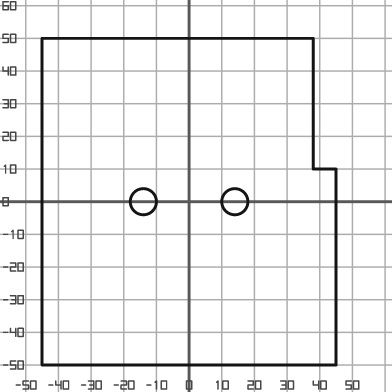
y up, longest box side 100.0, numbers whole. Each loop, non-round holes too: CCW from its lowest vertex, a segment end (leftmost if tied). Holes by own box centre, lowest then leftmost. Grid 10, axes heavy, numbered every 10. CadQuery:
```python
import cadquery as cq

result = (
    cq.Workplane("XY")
    .moveTo(-45.0, -50.0)
    .lineTo(45.0, -50.0)
    .lineTo(45.0, 10.0)
    .lineTo(38.0, 10.0)
    .lineTo(38.0, 50.0)
    .lineTo(-45.0, 50.0)
    .close()
    .moveTo(-14.0, 0.0)
    .circle(4.0)
    .moveTo(14.0, 0.0)
    .circle(4.0)
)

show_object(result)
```